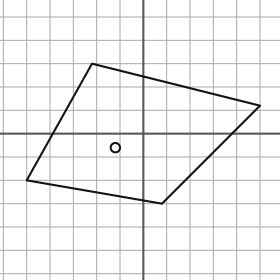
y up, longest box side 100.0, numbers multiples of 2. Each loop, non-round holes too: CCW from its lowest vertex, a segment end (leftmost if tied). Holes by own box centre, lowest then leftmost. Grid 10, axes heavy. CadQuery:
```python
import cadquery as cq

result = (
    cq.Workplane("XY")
    .moveTo(8.0, -30.0)
    .lineTo(50.0, 12.0)
    .lineTo(-22.0, 30.0)
    .lineTo(-50.0, -20.0)
    .close()
    .moveTo(-12.0, -6.0)
    .circle(2.0)
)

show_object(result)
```